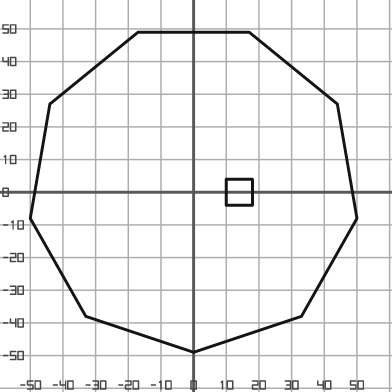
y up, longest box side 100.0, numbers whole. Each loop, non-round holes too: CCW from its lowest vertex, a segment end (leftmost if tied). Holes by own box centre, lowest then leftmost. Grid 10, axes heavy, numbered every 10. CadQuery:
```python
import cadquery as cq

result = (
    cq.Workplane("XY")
    .moveTo(0.0, -49.0)
    .lineTo(33.0, -38.0)
    .lineTo(50.0, -8.0)
    .lineTo(44.0, 27.0)
    .lineTo(17.0, 49.0)
    .lineTo(-17.0, 49.0)
    .lineTo(-44.0, 27.0)
    .lineTo(-50.0, -8.0)
    .lineTo(-33.0, -38.0)
    .close()
    .moveTo(10.0, -4.0)
    .lineTo(18.0, -4.0)
    .lineTo(18.0, 4.0)
    .lineTo(10.0, 4.0)
    .close()
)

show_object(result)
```